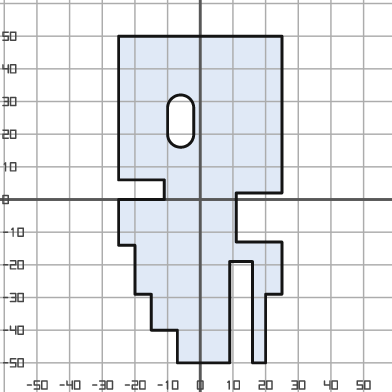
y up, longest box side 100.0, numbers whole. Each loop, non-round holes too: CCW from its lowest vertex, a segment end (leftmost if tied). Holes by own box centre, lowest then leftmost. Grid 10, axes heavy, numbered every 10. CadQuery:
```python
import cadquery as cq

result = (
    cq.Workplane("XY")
    .moveTo(-7.0, -50.0)
    .lineTo(9.0, -50.0)
    .lineTo(9.0, -19.0)
    .lineTo(16.0, -19.0)
    .lineTo(16.0, -50.0)
    .lineTo(20.0, -50.0)
    .lineTo(20.0, -29.0)
    .lineTo(25.0, -29.0)
    .lineTo(25.0, -13.0)
    .lineTo(11.0, -13.0)
    .lineTo(11.0, 2.0)
    .lineTo(25.0, 2.0)
    .lineTo(25.0, 50.0)
    .lineTo(-25.0, 50.0)
    .lineTo(-25.0, 6.0)
    .lineTo(-11.0, 6.0)
    .lineTo(-11.0, 0.0)
    .lineTo(-25.0, 0.0)
    .lineTo(-25.0, -14.0)
    .lineTo(-20.0, -14.0)
    .lineTo(-20.0, -29.0)
    .lineTo(-15.0, -29.0)
    .lineTo(-15.0, -40.0)
    .lineTo(-7.0, -40.0)
    .close()
    .moveTo(-10.0, 20.0)
    .threePointArc((-6.0, 16.0), (-2.0, 20.0))
    .lineTo(-2.0, 28.0)
    .threePointArc((-6.0, 32.0), (-10.0, 28.0))
    .close()
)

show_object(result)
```